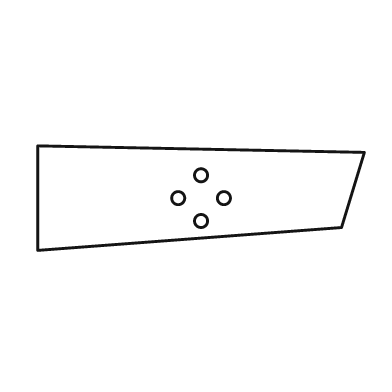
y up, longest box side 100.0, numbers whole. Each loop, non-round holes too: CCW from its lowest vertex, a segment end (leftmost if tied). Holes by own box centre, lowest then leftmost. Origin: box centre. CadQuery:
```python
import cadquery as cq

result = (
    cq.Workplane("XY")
    .moveTo(-50.0, -16.0)
    .lineTo(43.0, -9.0)
    .lineTo(50.0, 14.0)
    .lineTo(-50.0, 16.0)
    .close()
    .moveTo(0.0, -7.0)
    .circle(2.0)
    .moveTo(-7.0, 0.0)
    .circle(2.0)
    .moveTo(7.0, 0.0)
    .circle(2.0)
    .moveTo(0.0, 7.0)
    .circle(2.0)
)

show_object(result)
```